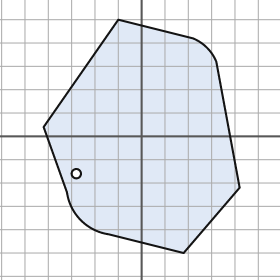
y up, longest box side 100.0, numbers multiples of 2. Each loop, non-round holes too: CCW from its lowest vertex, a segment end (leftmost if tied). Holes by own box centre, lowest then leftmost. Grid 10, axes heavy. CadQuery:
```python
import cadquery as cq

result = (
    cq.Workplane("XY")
    .moveTo(18.0, -50.0)
    .lineTo(42.0, -22.0)
    .lineTo(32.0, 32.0)
    .threePointArc((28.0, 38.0), (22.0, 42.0))
    .lineTo(-10.0, 50.0)
    .lineTo(-42.0, 4.0)
    .lineTo(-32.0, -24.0)
    .threePointArc((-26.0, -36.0), (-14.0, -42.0))
    .close()
    .moveTo(-28.0, -16.0)
    .circle(2.0)
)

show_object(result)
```